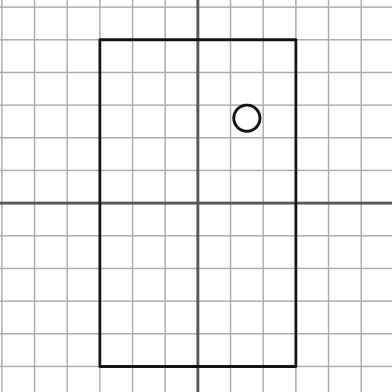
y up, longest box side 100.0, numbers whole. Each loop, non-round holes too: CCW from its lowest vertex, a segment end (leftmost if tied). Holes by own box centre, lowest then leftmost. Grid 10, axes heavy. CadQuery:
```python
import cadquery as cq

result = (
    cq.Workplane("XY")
    .moveTo(-30.0, -50.0)
    .lineTo(30.0, -50.0)
    .lineTo(30.0, 50.0)
    .lineTo(-30.0, 50.0)
    .close()
    .moveTo(15.0, 26.0)
    .circle(4.0)
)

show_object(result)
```